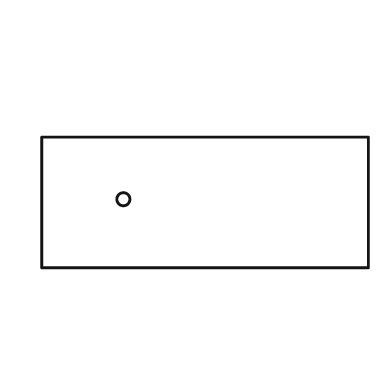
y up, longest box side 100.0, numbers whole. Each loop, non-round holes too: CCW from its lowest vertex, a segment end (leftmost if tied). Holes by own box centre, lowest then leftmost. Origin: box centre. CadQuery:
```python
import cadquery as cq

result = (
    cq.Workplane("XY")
    .moveTo(-50.0, -20.0)
    .lineTo(50.0, -20.0)
    .lineTo(50.0, 20.0)
    .lineTo(-50.0, 20.0)
    .close()
    .moveTo(-25.0, 1.0)
    .circle(2.0)
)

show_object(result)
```